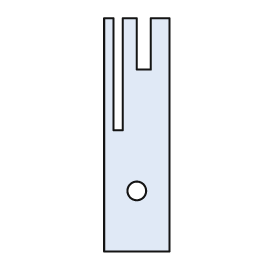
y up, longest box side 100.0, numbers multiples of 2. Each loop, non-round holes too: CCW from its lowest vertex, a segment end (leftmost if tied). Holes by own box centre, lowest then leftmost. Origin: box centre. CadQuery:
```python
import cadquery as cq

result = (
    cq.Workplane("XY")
    .moveTo(-14.0, -50.0)
    .lineTo(14.0, -50.0)
    .lineTo(14.0, 50.0)
    .lineTo(6.0, 50.0)
    .lineTo(6.0, 28.0)
    .lineTo(0.0, 28.0)
    .lineTo(0.0, 50.0)
    .lineTo(-6.0, 50.0)
    .lineTo(-6.0, 2.0)
    .lineTo(-10.0, 2.0)
    .lineTo(-10.0, 50.0)
    .lineTo(-14.0, 50.0)
    .close()
    .moveTo(0.0, -24.0)
    .circle(4.0)
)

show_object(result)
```